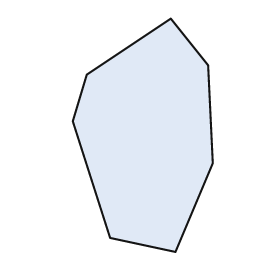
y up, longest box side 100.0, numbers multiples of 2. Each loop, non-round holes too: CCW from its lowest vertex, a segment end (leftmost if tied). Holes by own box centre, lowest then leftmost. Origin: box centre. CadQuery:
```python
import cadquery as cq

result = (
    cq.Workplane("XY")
    .moveTo(14.0, -50.0)
    .lineTo(30.0, -12.0)
    .lineTo(28.0, 30.0)
    .lineTo(12.0, 50.0)
    .lineTo(-24.0, 26.0)
    .lineTo(-30.0, 6.0)
    .lineTo(-14.0, -44.0)
    .close()
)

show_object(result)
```